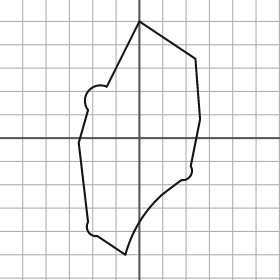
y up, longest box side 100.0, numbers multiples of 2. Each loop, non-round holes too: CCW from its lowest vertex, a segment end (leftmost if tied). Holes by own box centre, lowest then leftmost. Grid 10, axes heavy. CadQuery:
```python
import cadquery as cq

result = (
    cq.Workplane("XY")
    .moveTo(-6.0, -50.0)
    .threePointArc((0.0, -36.0), (10.0, -24.0))
    .lineTo(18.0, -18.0)
    .threePointArc((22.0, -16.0), (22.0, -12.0))
    .lineTo(26.0, 8.0)
    .lineTo(24.0, 34.0)
    .lineTo(0.0, 50.0)
    .lineTo(-14.0, 22.0)
    .threePointArc((-22.0, 20.0), (-22.0, 12.0))
    .lineTo(-26.0, -2.0)
    .lineTo(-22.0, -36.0)
    .threePointArc((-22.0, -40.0), (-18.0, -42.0))
    .close()
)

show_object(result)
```